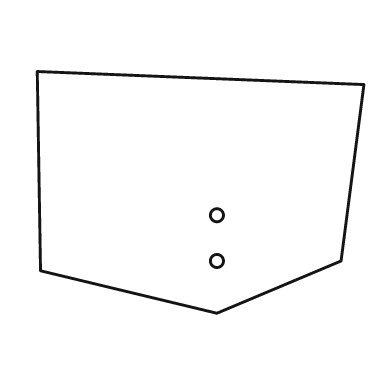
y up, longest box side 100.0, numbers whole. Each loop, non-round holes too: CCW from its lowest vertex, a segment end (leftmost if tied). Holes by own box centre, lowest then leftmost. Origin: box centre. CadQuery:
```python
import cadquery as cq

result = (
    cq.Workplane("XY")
    .moveTo(5.0, -37.0)
    .lineTo(43.0, -21.0)
    .lineTo(50.0, 33.0)
    .lineTo(-50.0, 37.0)
    .lineTo(-49.0, -24.0)
    .close()
    .moveTo(5.0, -21.0)
    .circle(2.0)
    .moveTo(5.0, -7.0)
    .circle(2.0)
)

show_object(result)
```